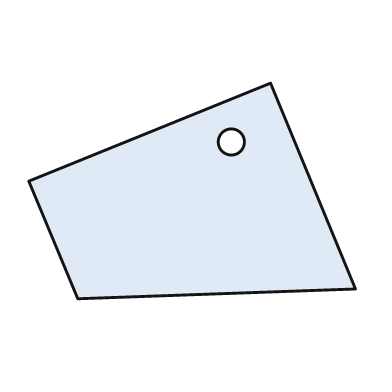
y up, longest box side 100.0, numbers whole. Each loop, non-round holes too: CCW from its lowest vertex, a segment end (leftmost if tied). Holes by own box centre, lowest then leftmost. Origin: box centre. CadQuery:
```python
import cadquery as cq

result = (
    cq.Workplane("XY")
    .moveTo(-35.0, -33.0)
    .lineTo(50.0, -30.0)
    .lineTo(24.0, 33.0)
    .lineTo(-50.0, 3.0)
    .close()
    .moveTo(12.0, 15.0)
    .circle(4.0)
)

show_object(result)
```